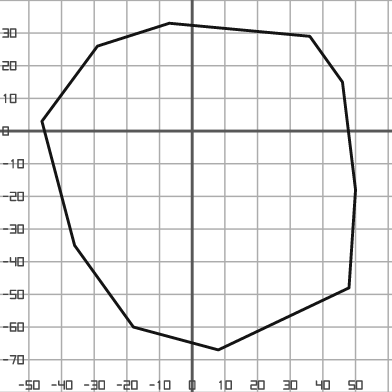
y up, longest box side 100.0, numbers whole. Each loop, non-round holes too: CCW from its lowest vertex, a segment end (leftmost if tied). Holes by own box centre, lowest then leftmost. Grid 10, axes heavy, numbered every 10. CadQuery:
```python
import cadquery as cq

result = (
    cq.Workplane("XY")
    .moveTo(8.0, -67.0)
    .lineTo(48.0, -48.0)
    .lineTo(50.0, -18.0)
    .lineTo(46.0, 15.0)
    .lineTo(36.0, 29.0)
    .lineTo(-7.0, 33.0)
    .lineTo(-29.0, 26.0)
    .lineTo(-46.0, 3.0)
    .lineTo(-36.0, -35.0)
    .lineTo(-18.0, -60.0)
    .close()
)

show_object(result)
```